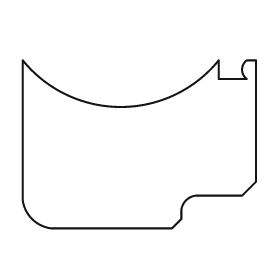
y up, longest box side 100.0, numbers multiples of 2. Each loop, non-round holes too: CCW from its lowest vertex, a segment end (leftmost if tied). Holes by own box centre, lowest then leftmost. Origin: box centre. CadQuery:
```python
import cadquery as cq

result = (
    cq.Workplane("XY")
    .moveTo(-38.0, -36.0)
    .lineTo(14.0, -36.0)
    .lineTo(18.0, -32.0)
    .lineTo(18.0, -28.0)
    .threePointArc((20.0, -24.0), (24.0, -22.0))
    .lineTo(44.0, -22.0)
    .lineTo(50.0, -16.0)
    .lineTo(50.0, 36.0)
    .lineTo(46.0, 36.0)
    .threePointArc((44.0, 32.0), (46.0, 28.0))
    .lineTo(34.0, 28.0)
    .lineTo(34.0, 36.0)
    .threePointArc((-8.0, 16.0), (-50.0, 36.0))
    .lineTo(-50.0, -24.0)
    .threePointArc((-46.0, -32.0), (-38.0, -36.0))
    .close()
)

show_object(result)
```